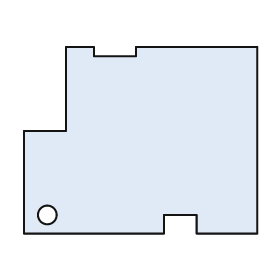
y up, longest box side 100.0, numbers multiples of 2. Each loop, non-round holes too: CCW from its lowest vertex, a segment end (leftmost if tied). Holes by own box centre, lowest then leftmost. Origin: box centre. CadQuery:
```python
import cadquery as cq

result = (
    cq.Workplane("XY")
    .moveTo(-50.0, -40.0)
    .lineTo(10.0, -40.0)
    .lineTo(10.0, -32.0)
    .lineTo(24.0, -32.0)
    .lineTo(24.0, -40.0)
    .lineTo(50.0, -40.0)
    .lineTo(50.0, 40.0)
    .lineTo(-2.0, 40.0)
    .lineTo(-2.0, 36.0)
    .lineTo(-20.0, 36.0)
    .lineTo(-20.0, 40.0)
    .lineTo(-32.0, 40.0)
    .lineTo(-32.0, 4.0)
    .lineTo(-50.0, 4.0)
    .close()
    .moveTo(-40.0, -32.0)
    .circle(4.0)
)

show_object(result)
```